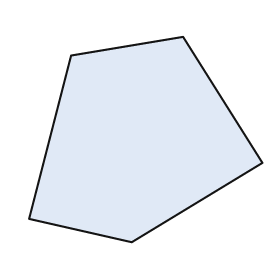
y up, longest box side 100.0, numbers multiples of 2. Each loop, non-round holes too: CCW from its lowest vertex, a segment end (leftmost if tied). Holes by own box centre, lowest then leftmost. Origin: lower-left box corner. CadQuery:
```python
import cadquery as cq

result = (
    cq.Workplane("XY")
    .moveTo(44.0, 0.0)
    .lineTo(100.0, 34.0)
    .lineTo(66.0, 88.0)
    .lineTo(18.0, 80.0)
    .lineTo(0.0, 10.0)
    .close()
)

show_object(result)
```